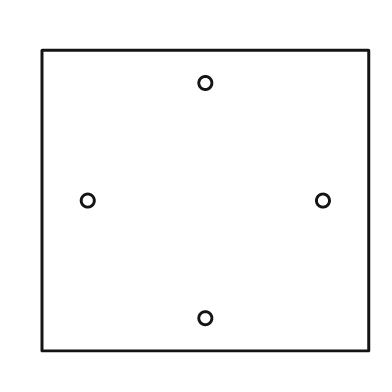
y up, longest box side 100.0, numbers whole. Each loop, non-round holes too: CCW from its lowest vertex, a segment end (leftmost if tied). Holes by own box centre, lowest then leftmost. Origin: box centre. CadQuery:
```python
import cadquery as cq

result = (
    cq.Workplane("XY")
    .moveTo(-50.0, -46.0)
    .lineTo(50.0, -46.0)
    .lineTo(50.0, 46.0)
    .lineTo(-50.0, 46.0)
    .close()
    .moveTo(0.0, -36.0)
    .circle(2.0)
    .moveTo(-36.0, 0.0)
    .circle(2.0)
    .moveTo(36.0, 0.0)
    .circle(2.0)
    .moveTo(0.0, 36.0)
    .circle(2.0)
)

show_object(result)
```